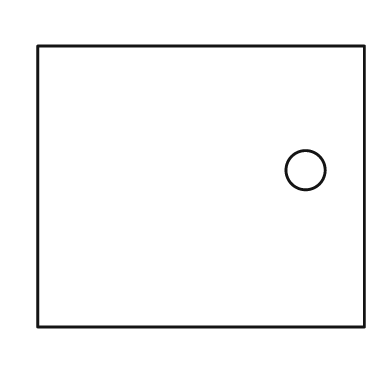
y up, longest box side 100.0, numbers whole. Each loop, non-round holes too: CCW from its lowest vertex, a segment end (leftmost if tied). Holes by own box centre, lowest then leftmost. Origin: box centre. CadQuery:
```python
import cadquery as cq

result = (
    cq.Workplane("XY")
    .moveTo(-50.0, -43.0)
    .lineTo(50.0, -43.0)
    .lineTo(50.0, 43.0)
    .lineTo(-50.0, 43.0)
    .close()
    .moveTo(32.0, 5.0)
    .circle(6.0)
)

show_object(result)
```